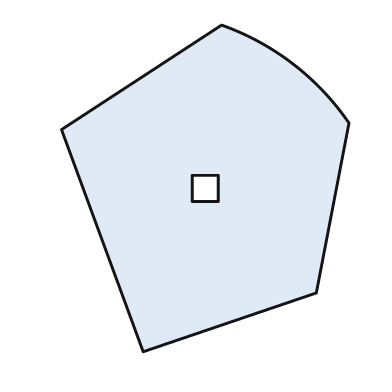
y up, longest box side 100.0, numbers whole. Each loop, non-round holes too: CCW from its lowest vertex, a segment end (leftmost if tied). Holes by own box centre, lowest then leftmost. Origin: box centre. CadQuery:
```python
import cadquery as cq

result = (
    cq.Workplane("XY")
    .moveTo(-19.0, -50.0)
    .lineTo(34.0, -32.0)
    .lineTo(44.0, 20.0)
    .threePointArc((27.0, 38.0), (5.0, 50.0))
    .lineTo(-44.0, 18.0)
    .close()
    .moveTo(-4.0, -4.0)
    .lineTo(4.0, -4.0)
    .lineTo(4.0, 4.0)
    .lineTo(-4.0, 4.0)
    .close()
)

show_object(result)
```